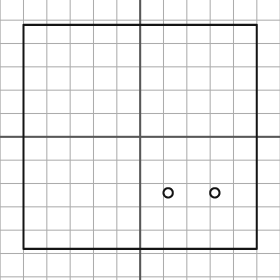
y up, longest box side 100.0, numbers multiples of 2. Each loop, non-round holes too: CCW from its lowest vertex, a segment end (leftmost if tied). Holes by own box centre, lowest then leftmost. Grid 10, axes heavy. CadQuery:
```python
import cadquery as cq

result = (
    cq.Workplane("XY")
    .moveTo(-50.0, -48.0)
    .lineTo(50.0, -48.0)
    .lineTo(50.0, 48.0)
    .lineTo(-50.0, 48.0)
    .close()
    .moveTo(12.0, -24.0)
    .circle(2.0)
    .moveTo(32.0, -24.0)
    .circle(2.0)
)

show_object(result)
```